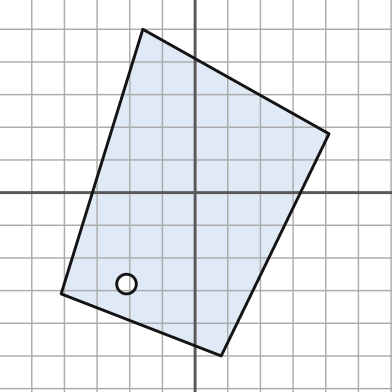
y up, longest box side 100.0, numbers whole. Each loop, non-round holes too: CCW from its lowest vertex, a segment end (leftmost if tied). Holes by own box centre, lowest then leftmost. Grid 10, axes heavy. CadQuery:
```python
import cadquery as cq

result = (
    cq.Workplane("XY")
    .moveTo(8.0, -50.0)
    .lineTo(41.0, 18.0)
    .lineTo(-16.0, 50.0)
    .lineTo(-41.0, -31.0)
    .close()
    .moveTo(-21.0, -28.0)
    .circle(3.0)
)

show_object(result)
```